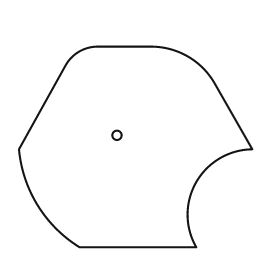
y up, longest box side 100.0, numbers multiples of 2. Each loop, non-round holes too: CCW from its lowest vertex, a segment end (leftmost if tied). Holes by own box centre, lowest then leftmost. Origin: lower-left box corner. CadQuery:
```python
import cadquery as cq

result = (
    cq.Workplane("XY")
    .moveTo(26.0, 0.0)
    .lineTo(76.0, 0.0)
    .threePointArc((76.0, 28.0), (100.0, 42.0))
    .lineTo(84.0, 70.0)
    .threePointArc((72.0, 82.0), (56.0, 86.0))
    .lineTo(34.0, 86.0)
    .threePointArc((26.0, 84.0), (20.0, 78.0))
    .lineTo(0.0, 42.0)
    .threePointArc((8.0, 18.0), (26.0, 0.0))
    .close()
    .moveTo(42.0, 48.0)
    .circle(2.0)
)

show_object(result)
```